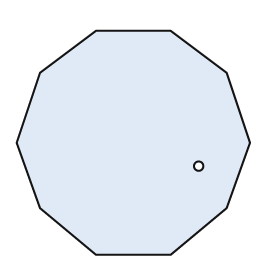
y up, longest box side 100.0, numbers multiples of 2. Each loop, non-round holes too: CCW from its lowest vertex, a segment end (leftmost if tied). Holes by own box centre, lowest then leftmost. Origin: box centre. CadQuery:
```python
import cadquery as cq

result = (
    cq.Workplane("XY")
    .moveTo(-16.0, -48.0)
    .lineTo(16.0, -48.0)
    .lineTo(40.0, -28.0)
    .lineTo(50.0, 0.0)
    .lineTo(40.0, 30.0)
    .lineTo(16.0, 48.0)
    .lineTo(-16.0, 48.0)
    .lineTo(-40.0, 30.0)
    .lineTo(-50.0, 0.0)
    .lineTo(-40.0, -28.0)
    .close()
    .moveTo(28.0, -10.0)
    .circle(2.0)
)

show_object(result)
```